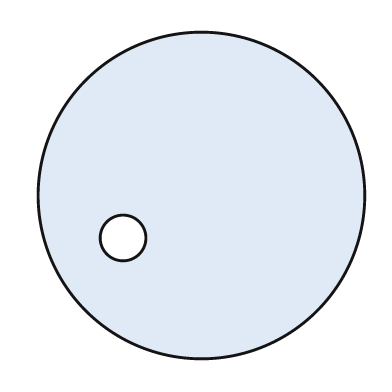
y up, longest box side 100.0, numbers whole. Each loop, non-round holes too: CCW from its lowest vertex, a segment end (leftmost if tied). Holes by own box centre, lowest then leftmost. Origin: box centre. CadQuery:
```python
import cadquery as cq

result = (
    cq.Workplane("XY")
    .moveTo(0.0, 0.0)
    .circle(50.0)
    .moveTo(-24.0, -13.0)
    .circle(7.0)
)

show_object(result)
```